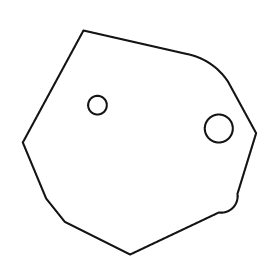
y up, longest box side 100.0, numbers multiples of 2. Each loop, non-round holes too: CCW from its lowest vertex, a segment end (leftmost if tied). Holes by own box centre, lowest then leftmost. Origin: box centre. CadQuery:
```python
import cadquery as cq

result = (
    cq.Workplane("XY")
    .moveTo(-4.0, -48.0)
    .lineTo(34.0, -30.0)
    .threePointArc((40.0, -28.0), (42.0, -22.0))
    .lineTo(50.0, 4.0)
    .lineTo(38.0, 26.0)
    .threePointArc((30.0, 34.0), (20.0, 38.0))
    .lineTo(-24.0, 48.0)
    .lineTo(-50.0, 0.0)
    .lineTo(-40.0, -24.0)
    .lineTo(-32.0, -34.0)
    .close()
    .moveTo(34.0, 6.0)
    .circle(6.0)
    .moveTo(-18.0, 16.0)
    .circle(4.0)
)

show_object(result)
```